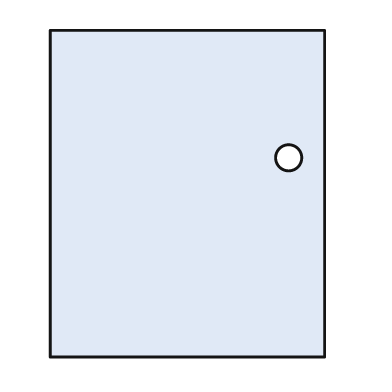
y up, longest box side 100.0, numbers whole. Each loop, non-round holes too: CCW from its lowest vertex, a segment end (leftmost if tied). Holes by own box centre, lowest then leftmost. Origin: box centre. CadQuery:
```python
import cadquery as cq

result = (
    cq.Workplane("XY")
    .moveTo(-42.0, -50.0)
    .lineTo(42.0, -50.0)
    .lineTo(42.0, 50.0)
    .lineTo(-42.0, 50.0)
    .close()
    .moveTo(31.0, 11.0)
    .circle(4.0)
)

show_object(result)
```